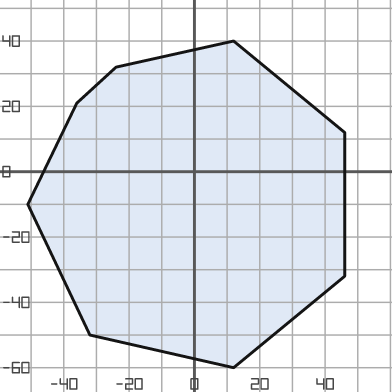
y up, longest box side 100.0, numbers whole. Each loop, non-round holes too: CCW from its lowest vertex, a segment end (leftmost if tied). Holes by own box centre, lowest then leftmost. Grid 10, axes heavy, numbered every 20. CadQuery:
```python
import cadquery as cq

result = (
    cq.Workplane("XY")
    .moveTo(12.0, -60.0)
    .lineTo(46.0, -32.0)
    .lineTo(46.0, 12.0)
    .lineTo(12.0, 40.0)
    .lineTo(-24.0, 32.0)
    .lineTo(-36.0, 21.0)
    .lineTo(-51.0, -10.0)
    .lineTo(-32.0, -50.0)
    .close()
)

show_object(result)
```